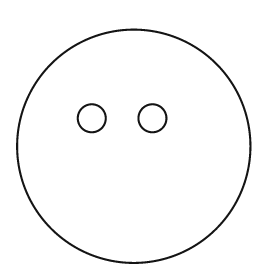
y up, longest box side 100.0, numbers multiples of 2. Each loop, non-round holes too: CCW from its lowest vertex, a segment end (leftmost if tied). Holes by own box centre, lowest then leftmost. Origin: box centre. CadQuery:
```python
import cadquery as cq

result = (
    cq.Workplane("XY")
    .moveTo(0.0, 0.0)
    .circle(50.0)
    .moveTo(-18.0, 12.0)
    .circle(6.0)
    .moveTo(8.0, 12.0)
    .circle(6.0)
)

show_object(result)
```